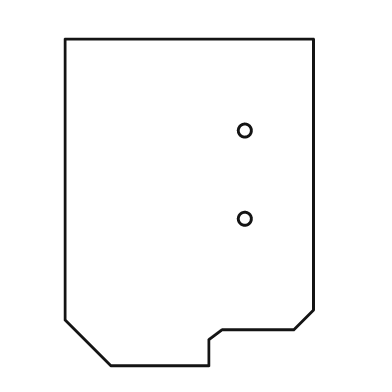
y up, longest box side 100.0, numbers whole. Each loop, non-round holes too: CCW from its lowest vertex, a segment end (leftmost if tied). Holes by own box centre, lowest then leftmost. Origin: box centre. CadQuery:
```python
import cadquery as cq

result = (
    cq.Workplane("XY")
    .moveTo(-24.0, -50.0)
    .lineTo(6.0, -50.0)
    .lineTo(6.0, -42.0)
    .lineTo(10.0, -39.0)
    .lineTo(32.0, -39.0)
    .lineTo(38.0, -33.0)
    .lineTo(38.0, 50.0)
    .lineTo(-38.0, 50.0)
    .lineTo(-38.0, -36.0)
    .close()
    .moveTo(17.0, -5.0)
    .circle(2.0)
    .moveTo(17.0, 22.0)
    .circle(2.0)
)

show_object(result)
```